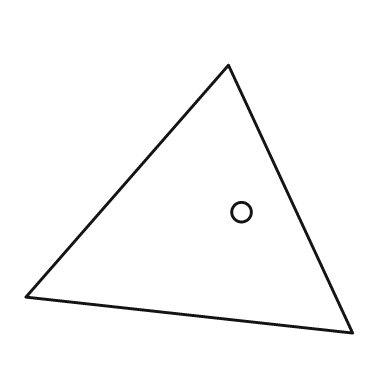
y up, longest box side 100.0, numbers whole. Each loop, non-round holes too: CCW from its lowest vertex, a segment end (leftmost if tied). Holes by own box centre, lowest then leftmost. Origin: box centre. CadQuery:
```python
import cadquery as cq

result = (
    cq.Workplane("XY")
    .moveTo(50.0, -41.0)
    .lineTo(12.0, 41.0)
    .lineTo(-50.0, -30.0)
    .close()
    .moveTo(16.0, -4.0)
    .circle(3.0)
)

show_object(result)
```